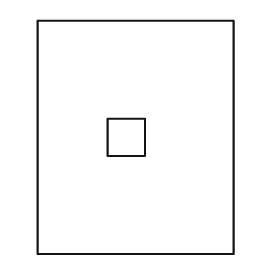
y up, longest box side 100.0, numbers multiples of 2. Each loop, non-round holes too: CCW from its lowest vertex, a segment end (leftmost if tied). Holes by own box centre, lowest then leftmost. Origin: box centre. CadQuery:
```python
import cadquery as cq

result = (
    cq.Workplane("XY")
    .moveTo(-42.0, -50.0)
    .lineTo(42.0, -50.0)
    .lineTo(42.0, 50.0)
    .lineTo(-42.0, 50.0)
    .close()
    .moveTo(-12.0, -8.0)
    .lineTo(4.0, -8.0)
    .lineTo(4.0, 8.0)
    .lineTo(-12.0, 8.0)
    .close()
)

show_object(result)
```